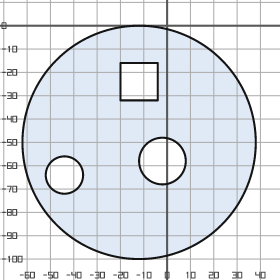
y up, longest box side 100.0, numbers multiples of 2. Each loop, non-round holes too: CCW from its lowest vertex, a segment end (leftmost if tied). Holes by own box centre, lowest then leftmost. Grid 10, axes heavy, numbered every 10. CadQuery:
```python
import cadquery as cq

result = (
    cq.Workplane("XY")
    .moveTo(-12.0, -50.0)
    .circle(50.0)
    .moveTo(-44.0, -64.0)
    .circle(8.0)
    .moveTo(-2.0, -58.0)
    .circle(10.0)
    .moveTo(-20.0, -32.0)
    .lineTo(-4.0, -32.0)
    .lineTo(-4.0, -16.0)
    .lineTo(-20.0, -16.0)
    .close()
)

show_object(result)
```